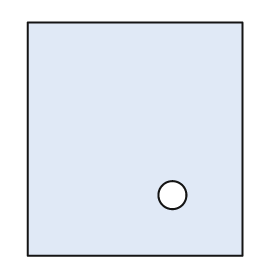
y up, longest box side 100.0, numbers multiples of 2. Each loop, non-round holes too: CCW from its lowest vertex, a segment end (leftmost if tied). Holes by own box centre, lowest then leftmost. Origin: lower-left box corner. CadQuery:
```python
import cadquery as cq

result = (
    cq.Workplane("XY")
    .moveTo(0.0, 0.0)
    .lineTo(92.0, 0.0)
    .lineTo(92.0, 100.0)
    .lineTo(0.0, 100.0)
    .close()
    .moveTo(62.0, 26.0)
    .circle(6.0)
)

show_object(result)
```